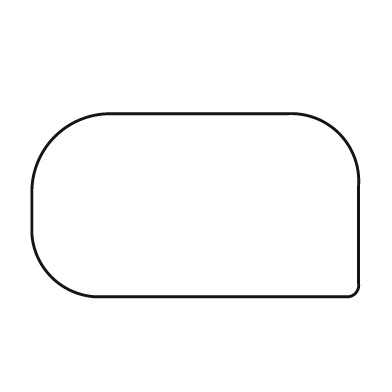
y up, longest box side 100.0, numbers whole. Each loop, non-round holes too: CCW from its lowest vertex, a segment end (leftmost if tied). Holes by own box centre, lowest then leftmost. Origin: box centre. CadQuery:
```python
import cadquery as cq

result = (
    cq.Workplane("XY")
    .moveTo(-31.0, -28.0)
    .lineTo(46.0, -28.0)
    .threePointArc((49.0, -27.0), (50.0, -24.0))
    .lineTo(50.0, 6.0)
    .threePointArc((44.0, 22.0), (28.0, 28.0))
    .lineTo(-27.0, 28.0)
    .threePointArc((-43.0, 21.0), (-50.0, 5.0))
    .lineTo(-50.0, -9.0)
    .threePointArc((-44.0, -22.0), (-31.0, -28.0))
    .close()
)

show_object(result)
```